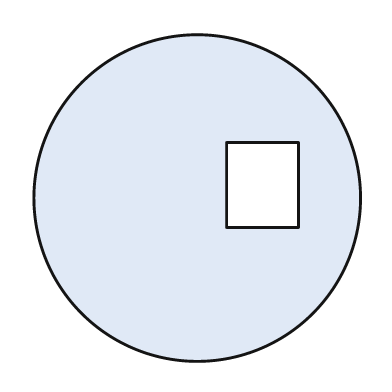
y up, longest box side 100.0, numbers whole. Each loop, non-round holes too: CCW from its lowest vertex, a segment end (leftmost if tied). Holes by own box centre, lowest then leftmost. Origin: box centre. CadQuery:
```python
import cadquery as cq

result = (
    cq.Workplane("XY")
    .moveTo(0.0, 0.0)
    .circle(50.0)
    .moveTo(9.0, -9.0)
    .lineTo(31.0, -9.0)
    .lineTo(31.0, 17.0)
    .lineTo(9.0, 17.0)
    .close()
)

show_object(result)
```